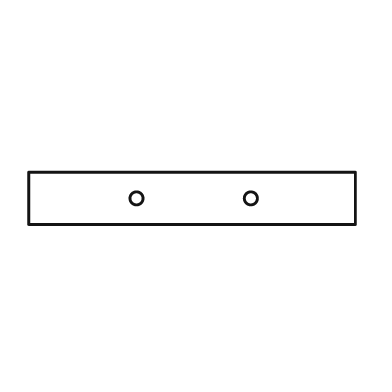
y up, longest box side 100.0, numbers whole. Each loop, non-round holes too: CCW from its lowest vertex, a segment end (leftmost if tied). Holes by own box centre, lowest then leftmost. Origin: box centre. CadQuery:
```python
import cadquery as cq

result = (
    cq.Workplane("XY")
    .moveTo(-50.0, -8.0)
    .lineTo(50.0, -8.0)
    .lineTo(50.0, 8.0)
    .lineTo(-50.0, 8.0)
    .close()
    .moveTo(-17.0, 0.0)
    .circle(2.0)
    .moveTo(18.0, 0.0)
    .circle(2.0)
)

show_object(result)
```